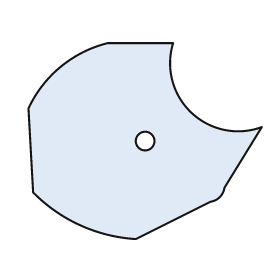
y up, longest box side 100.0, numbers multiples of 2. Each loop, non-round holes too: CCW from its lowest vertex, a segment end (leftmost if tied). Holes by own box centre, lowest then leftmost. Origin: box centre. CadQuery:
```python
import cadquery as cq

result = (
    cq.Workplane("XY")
    .moveTo(-4.0, -42.0)
    .lineTo(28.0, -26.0)
    .threePointArc((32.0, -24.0), (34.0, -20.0))
    .lineTo(50.0, 6.0)
    .threePointArc((20.0, 12.0), (12.0, 42.0))
    .lineTo(-16.0, 42.0)
    .threePointArc((-36.0, 32.0), (-50.0, 14.0))
    .lineTo(-48.0, -22.0)
    .threePointArc((-28.0, -36.0), (-4.0, -42.0))
    .close()
    .moveTo(0.0, 0.0)
    .circle(4.0)
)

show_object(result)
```